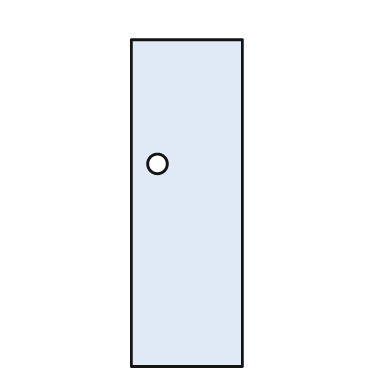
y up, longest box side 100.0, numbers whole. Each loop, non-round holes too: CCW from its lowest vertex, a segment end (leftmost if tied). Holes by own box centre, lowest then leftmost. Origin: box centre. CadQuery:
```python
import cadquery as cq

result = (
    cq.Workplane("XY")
    .moveTo(-17.0, -50.0)
    .lineTo(17.0, -50.0)
    .lineTo(17.0, 50.0)
    .lineTo(-17.0, 50.0)
    .close()
    .moveTo(-9.0, 12.0)
    .circle(3.0)
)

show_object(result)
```